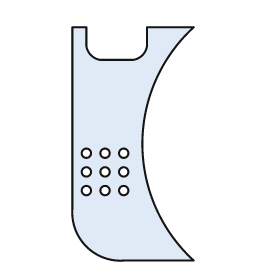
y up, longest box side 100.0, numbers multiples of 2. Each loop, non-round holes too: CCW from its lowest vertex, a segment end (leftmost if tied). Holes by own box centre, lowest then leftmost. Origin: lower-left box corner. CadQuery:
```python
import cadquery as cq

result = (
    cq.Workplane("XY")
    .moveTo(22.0, 0.0)
    .lineTo(52.0, 0.0)
    .threePointArc((30.0, 50.0), (52.0, 100.0))
    .lineTo(32.0, 100.0)
    .lineTo(32.0, 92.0)
    .threePointArc((30.0, 88.0), (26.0, 86.0))
    .lineTo(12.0, 86.0)
    .threePointArc((8.0, 88.0), (6.0, 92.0))
    .lineTo(6.0, 100.0)
    .lineTo(0.0, 100.0)
    .lineTo(0.0, 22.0)
    .threePointArc((6.0, 6.0), (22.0, 0.0))
    .close()
    .moveTo(6.0, 30.0)
    .circle(2.0)
    .moveTo(14.0, 30.0)
    .circle(2.0)
    .moveTo(22.0, 30.0)
    .circle(2.0)
    .moveTo(6.0, 38.0)
    .circle(2.0)
    .moveTo(14.0, 38.0)
    .circle(2.0)
    .moveTo(22.0, 38.0)
    .circle(2.0)
    .moveTo(6.0, 46.0)
    .circle(2.0)
    .moveTo(14.0, 46.0)
    .circle(2.0)
    .moveTo(22.0, 46.0)
    .circle(2.0)
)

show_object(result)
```